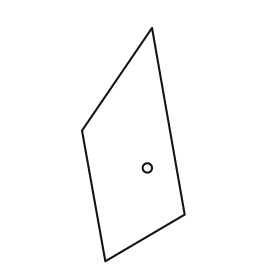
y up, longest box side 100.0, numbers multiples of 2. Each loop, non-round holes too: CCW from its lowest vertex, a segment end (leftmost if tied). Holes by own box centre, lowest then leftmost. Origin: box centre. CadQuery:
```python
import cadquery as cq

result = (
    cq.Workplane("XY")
    .moveTo(-12.0, -50.0)
    .lineTo(22.0, -30.0)
    .lineTo(8.0, 50.0)
    .lineTo(-22.0, 6.0)
    .close()
    .moveTo(6.0, -10.0)
    .circle(2.0)
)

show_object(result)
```